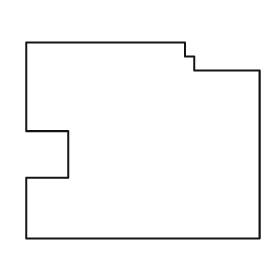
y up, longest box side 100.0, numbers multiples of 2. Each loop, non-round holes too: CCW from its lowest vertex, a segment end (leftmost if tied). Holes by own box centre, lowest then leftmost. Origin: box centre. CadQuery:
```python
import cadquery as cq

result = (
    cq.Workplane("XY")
    .moveTo(-50.0, -42.0)
    .lineTo(50.0, -42.0)
    .lineTo(50.0, 30.0)
    .lineTo(22.0, 30.0)
    .lineTo(22.0, 36.0)
    .lineTo(18.0, 36.0)
    .lineTo(18.0, 42.0)
    .lineTo(-50.0, 42.0)
    .lineTo(-50.0, 4.0)
    .lineTo(-32.0, 4.0)
    .lineTo(-32.0, -16.0)
    .lineTo(-50.0, -16.0)
    .close()
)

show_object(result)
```